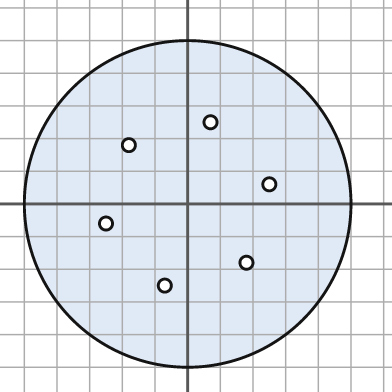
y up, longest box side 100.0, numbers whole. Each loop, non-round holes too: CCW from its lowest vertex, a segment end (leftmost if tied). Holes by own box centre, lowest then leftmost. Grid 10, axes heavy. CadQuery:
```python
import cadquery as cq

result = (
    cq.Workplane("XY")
    .moveTo(0.0, 0.0)
    .circle(50.0)
    .moveTo(-7.0, -25.0)
    .circle(2.0)
    .moveTo(18.0, -18.0)
    .circle(2.0)
    .moveTo(-25.0, -6.0)
    .circle(2.0)
    .moveTo(25.0, 6.0)
    .circle(2.0)
    .moveTo(-18.0, 18.0)
    .circle(2.0)
    .moveTo(7.0, 25.0)
    .circle(2.0)
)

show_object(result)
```